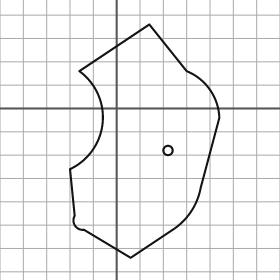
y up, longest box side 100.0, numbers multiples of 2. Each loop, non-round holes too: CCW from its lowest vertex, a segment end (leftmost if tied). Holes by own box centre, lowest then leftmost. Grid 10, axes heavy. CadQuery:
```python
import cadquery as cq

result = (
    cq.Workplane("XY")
    .moveTo(6.0, -64.0)
    .lineTo(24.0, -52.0)
    .threePointArc((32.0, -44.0), (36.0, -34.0))
    .lineTo(44.0, -4.0)
    .threePointArc((40.0, 8.0), (30.0, 16.0))
    .lineTo(14.0, 36.0)
    .lineTo(-16.0, 16.0)
    .threePointArc((-6.0, -6.0), (-20.0, -26.0))
    .lineTo(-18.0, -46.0)
    .threePointArc((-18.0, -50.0), (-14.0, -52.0))
    .close()
    .moveTo(22.0, -18.0)
    .circle(2.0)
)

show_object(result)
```